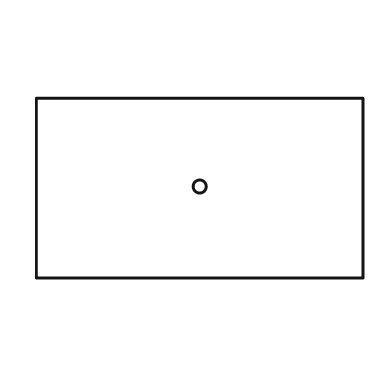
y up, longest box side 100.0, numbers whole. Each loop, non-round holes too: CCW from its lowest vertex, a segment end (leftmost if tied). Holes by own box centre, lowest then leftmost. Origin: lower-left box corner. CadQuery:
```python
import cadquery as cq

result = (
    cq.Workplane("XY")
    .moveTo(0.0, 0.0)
    .lineTo(100.0, 0.0)
    .lineTo(100.0, 55.0)
    .lineTo(0.0, 55.0)
    .close()
    .moveTo(50.0, 28.0)
    .circle(2.0)
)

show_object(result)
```